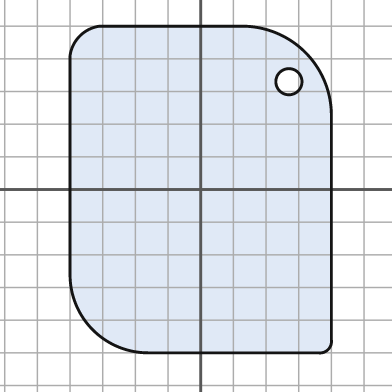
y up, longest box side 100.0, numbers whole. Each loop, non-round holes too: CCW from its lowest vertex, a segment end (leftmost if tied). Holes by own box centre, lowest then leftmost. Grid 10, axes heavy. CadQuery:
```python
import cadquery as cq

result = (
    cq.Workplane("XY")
    .moveTo(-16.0, -50.0)
    .lineTo(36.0, -50.0)
    .threePointArc((39.0, -49.0), (40.0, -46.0))
    .lineTo(40.0, 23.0)
    .threePointArc((32.0, 42.0), (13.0, 50.0))
    .lineTo(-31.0, 50.0)
    .threePointArc((-37.0, 47.0), (-40.0, 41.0))
    .lineTo(-40.0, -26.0)
    .threePointArc((-33.0, -43.0), (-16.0, -50.0))
    .close()
    .moveTo(27.0, 33.0)
    .circle(4.0)
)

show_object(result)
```